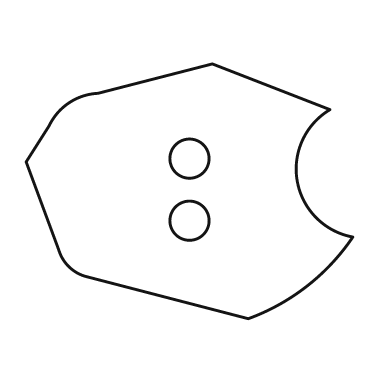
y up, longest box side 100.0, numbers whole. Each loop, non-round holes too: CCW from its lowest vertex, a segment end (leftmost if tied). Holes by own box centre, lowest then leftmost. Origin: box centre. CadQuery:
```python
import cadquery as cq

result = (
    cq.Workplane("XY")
    .moveTo(18.0, -39.0)
    .threePointArc((36.0, -29.0), (50.0, -14.0))
    .threePointArc((33.0, 3.0), (43.0, 25.0))
    .lineTo(7.0, 39.0)
    .lineTo(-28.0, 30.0)
    .threePointArc((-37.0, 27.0), (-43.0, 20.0))
    .lineTo(-50.0, 9.0)
    .lineTo(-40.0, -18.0)
    .threePointArc((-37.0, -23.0), (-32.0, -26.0))
    .close()
    .moveTo(0.0, -9.0)
    .circle(6.0)
    .moveTo(0.0, 10.0)
    .circle(6.0)
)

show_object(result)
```